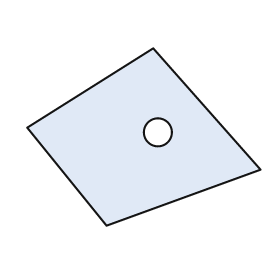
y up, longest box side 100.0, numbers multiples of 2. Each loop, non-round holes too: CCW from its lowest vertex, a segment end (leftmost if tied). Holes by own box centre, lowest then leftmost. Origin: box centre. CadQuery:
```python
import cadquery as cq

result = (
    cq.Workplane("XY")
    .moveTo(-16.0, -38.0)
    .lineTo(50.0, -14.0)
    .lineTo(4.0, 38.0)
    .lineTo(-50.0, 4.0)
    .close()
    .moveTo(6.0, 2.0)
    .circle(6.0)
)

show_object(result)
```